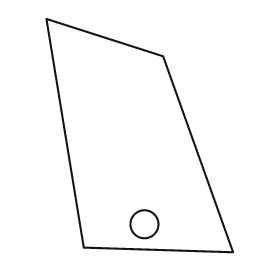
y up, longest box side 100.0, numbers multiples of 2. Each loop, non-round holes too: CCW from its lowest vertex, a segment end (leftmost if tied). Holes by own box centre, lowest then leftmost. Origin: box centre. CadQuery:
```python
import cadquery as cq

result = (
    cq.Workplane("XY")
    .moveTo(40.0, -50.0)
    .lineTo(10.0, 34.0)
    .lineTo(-40.0, 50.0)
    .lineTo(-24.0, -48.0)
    .close()
    .moveTo(2.0, -38.0)
    .circle(6.0)
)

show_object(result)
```